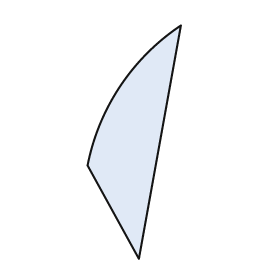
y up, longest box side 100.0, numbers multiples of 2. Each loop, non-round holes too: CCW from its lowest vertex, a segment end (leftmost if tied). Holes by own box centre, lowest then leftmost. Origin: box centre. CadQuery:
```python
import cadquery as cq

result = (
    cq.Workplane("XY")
    .moveTo(2.0, -50.0)
    .lineTo(20.0, 50.0)
    .threePointArc((-6.0, 24.0), (-20.0, -10.0))
    .close()
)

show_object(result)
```